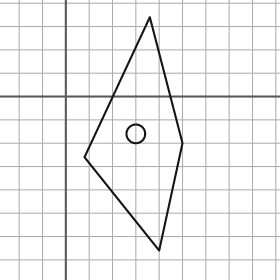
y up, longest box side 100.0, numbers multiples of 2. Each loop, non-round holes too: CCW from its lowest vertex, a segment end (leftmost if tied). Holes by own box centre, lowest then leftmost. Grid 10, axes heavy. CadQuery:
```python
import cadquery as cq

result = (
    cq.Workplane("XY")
    .moveTo(40.0, -66.0)
    .lineTo(50.0, -20.0)
    .lineTo(36.0, 34.0)
    .lineTo(8.0, -26.0)
    .close()
    .moveTo(30.0, -16.0)
    .circle(4.0)
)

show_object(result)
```